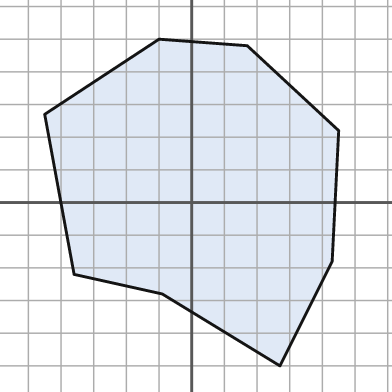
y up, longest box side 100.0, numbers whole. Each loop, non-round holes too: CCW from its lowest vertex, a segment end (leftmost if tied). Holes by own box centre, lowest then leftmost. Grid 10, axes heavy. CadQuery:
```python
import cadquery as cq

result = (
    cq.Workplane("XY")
    .moveTo(27.0, -50.0)
    .lineTo(43.0, -18.0)
    .lineTo(45.0, 22.0)
    .lineTo(17.0, 48.0)
    .lineTo(-10.0, 50.0)
    .lineTo(-45.0, 27.0)
    .lineTo(-36.0, -22.0)
    .lineTo(-9.0, -28.0)
    .close()
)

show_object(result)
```